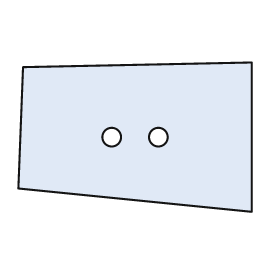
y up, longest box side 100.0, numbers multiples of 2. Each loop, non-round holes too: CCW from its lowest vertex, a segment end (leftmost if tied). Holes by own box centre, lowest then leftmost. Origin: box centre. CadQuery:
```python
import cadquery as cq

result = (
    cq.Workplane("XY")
    .moveTo(50.0, -32.0)
    .lineTo(50.0, 32.0)
    .lineTo(-48.0, 30.0)
    .lineTo(-50.0, -22.0)
    .close()
    .moveTo(-10.0, 0.0)
    .circle(4.0)
    .moveTo(10.0, 0.0)
    .circle(4.0)
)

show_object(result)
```